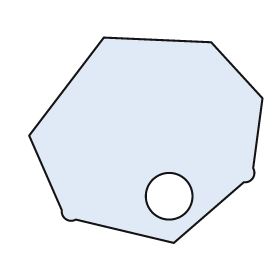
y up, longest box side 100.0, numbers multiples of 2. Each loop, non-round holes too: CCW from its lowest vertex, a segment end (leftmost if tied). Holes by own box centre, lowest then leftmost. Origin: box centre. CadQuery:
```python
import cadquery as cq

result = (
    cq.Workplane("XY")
    .moveTo(12.0, -44.0)
    .lineTo(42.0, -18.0)
    .threePointArc((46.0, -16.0), (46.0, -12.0))
    .lineTo(50.0, 18.0)
    .lineTo(28.0, 42.0)
    .lineTo(-18.0, 44.0)
    .lineTo(-50.0, 2.0)
    .lineTo(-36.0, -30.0)
    .threePointArc((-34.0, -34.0), (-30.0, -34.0))
    .close()
    .moveTo(10.0, -24.0)
    .circle(10.0)
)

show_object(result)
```